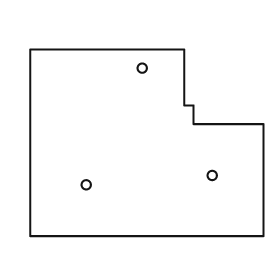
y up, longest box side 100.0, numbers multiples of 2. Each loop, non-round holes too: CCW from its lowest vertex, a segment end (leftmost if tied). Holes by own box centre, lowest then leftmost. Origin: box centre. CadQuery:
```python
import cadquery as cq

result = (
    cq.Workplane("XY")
    .moveTo(-50.0, -40.0)
    .lineTo(50.0, -40.0)
    .lineTo(50.0, 8.0)
    .lineTo(20.0, 8.0)
    .lineTo(20.0, 16.0)
    .lineTo(16.0, 16.0)
    .lineTo(16.0, 40.0)
    .lineTo(-50.0, 40.0)
    .close()
    .moveTo(-26.0, -18.0)
    .circle(2.0)
    .moveTo(28.0, -14.0)
    .circle(2.0)
    .moveTo(-2.0, 32.0)
    .circle(2.0)
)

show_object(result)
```